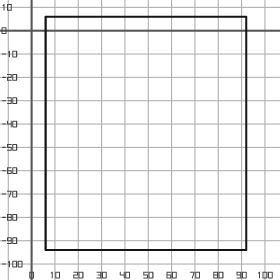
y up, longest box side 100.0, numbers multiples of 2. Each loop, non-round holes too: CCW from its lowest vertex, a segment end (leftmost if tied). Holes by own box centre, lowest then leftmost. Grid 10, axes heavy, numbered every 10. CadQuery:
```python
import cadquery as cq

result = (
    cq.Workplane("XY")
    .moveTo(6.0, -94.0)
    .lineTo(92.0, -94.0)
    .lineTo(92.0, 6.0)
    .lineTo(6.0, 6.0)
    .close()
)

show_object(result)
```